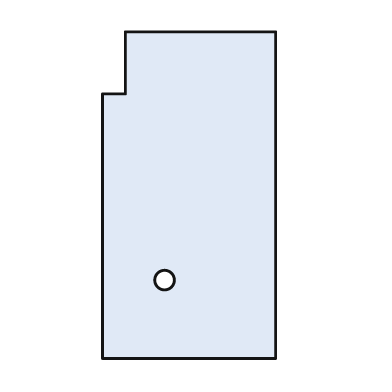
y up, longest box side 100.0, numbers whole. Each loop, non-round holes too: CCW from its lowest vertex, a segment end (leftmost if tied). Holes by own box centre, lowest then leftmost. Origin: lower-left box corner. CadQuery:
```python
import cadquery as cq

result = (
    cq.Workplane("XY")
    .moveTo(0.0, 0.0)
    .lineTo(53.0, 0.0)
    .lineTo(53.0, 100.0)
    .lineTo(7.0, 100.0)
    .lineTo(7.0, 81.0)
    .lineTo(0.0, 81.0)
    .close()
    .moveTo(19.0, 24.0)
    .circle(3.0)
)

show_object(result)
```